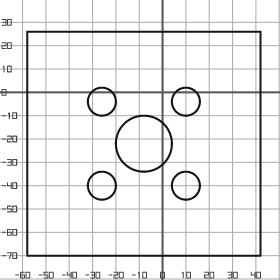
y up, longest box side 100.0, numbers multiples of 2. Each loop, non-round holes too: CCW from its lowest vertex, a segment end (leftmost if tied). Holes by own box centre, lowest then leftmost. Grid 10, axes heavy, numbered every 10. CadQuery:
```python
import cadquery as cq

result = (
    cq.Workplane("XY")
    .moveTo(-58.0, -70.0)
    .lineTo(42.0, -70.0)
    .lineTo(42.0, 26.0)
    .lineTo(-58.0, 26.0)
    .close()
    .moveTo(-26.0, -40.0)
    .circle(6.0)
    .moveTo(10.0, -40.0)
    .circle(6.0)
    .moveTo(-8.0, -22.0)
    .circle(12.0)
    .moveTo(-26.0, -4.0)
    .circle(6.0)
    .moveTo(10.0, -4.0)
    .circle(6.0)
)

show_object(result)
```